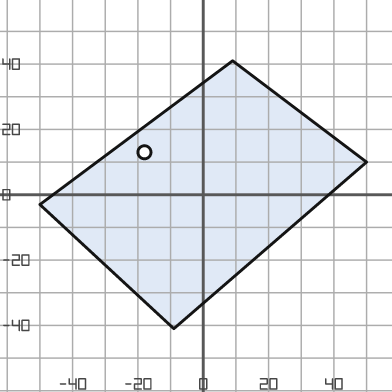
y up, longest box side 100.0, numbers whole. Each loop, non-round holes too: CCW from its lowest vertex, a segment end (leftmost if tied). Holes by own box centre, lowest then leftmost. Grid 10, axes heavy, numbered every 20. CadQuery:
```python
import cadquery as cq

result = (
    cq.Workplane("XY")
    .moveTo(-9.0, -41.0)
    .lineTo(50.0, 10.0)
    .lineTo(9.0, 41.0)
    .lineTo(-50.0, -3.0)
    .close()
    .moveTo(-18.0, 13.0)
    .circle(2.0)
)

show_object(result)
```